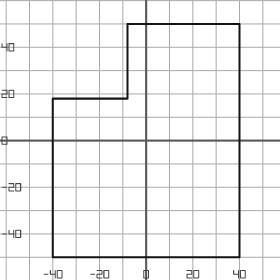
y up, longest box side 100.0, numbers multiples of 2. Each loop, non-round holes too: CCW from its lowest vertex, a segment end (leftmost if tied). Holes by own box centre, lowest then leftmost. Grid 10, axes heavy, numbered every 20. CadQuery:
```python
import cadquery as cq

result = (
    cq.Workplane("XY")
    .moveTo(-40.0, -50.0)
    .lineTo(40.0, -50.0)
    .lineTo(40.0, 50.0)
    .lineTo(-8.0, 50.0)
    .lineTo(-8.0, 18.0)
    .lineTo(-40.0, 18.0)
    .close()
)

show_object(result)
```